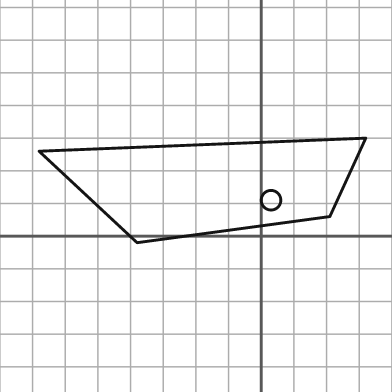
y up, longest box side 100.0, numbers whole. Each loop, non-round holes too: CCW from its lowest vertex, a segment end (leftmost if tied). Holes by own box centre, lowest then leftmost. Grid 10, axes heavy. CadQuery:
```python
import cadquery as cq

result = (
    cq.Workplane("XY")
    .moveTo(-38.0, -2.0)
    .lineTo(21.0, 6.0)
    .lineTo(32.0, 30.0)
    .lineTo(-68.0, 26.0)
    .close()
    .moveTo(3.0, 11.0)
    .circle(3.0)
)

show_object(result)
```